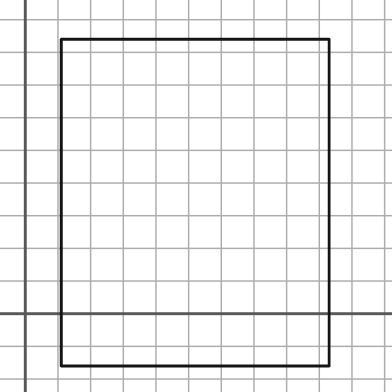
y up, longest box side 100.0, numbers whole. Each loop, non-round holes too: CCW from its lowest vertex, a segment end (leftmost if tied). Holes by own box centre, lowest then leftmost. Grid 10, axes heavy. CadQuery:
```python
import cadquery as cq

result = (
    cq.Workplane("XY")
    .moveTo(11.0, -16.0)
    .lineTo(93.0, -16.0)
    .lineTo(93.0, 84.0)
    .lineTo(11.0, 84.0)
    .close()
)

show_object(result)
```